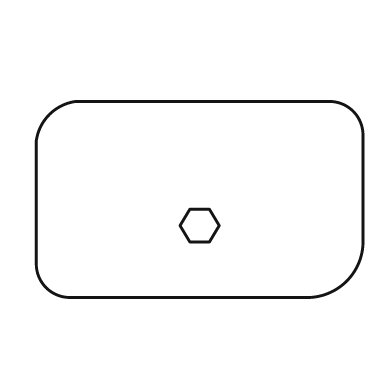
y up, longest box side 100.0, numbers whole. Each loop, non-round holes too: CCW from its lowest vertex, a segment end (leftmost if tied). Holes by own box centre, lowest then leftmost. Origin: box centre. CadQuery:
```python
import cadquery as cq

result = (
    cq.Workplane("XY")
    .moveTo(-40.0, -30.0)
    .lineTo(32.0, -30.0)
    .threePointArc((45.0, -25.0), (50.0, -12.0))
    .lineTo(50.0, 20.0)
    .threePointArc((47.0, 27.0), (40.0, 30.0))
    .lineTo(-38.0, 30.0)
    .threePointArc((-46.0, 26.0), (-50.0, 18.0))
    .lineTo(-50.0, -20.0)
    .threePointArc((-47.0, -27.0), (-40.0, -30.0))
    .close()
    .moveTo(-3.0, -13.0)
    .lineTo(3.0, -13.0)
    .lineTo(6.0, -8.0)
    .lineTo(3.0, -3.0)
    .lineTo(-3.0, -3.0)
    .lineTo(-6.0, -8.0)
    .close()
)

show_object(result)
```